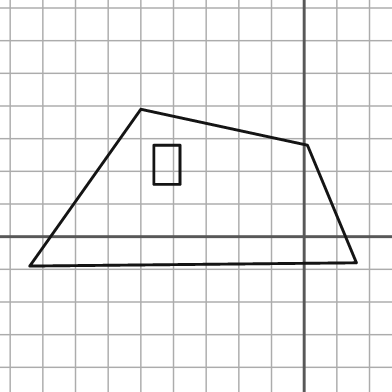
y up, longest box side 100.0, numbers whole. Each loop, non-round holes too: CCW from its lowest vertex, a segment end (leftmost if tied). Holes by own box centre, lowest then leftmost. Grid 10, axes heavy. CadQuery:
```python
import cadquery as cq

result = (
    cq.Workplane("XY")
    .moveTo(-84.0, -9.0)
    .lineTo(16.0, -8.0)
    .lineTo(1.0, 28.0)
    .lineTo(-50.0, 39.0)
    .close()
    .moveTo(-46.0, 16.0)
    .lineTo(-38.0, 16.0)
    .lineTo(-38.0, 28.0)
    .lineTo(-46.0, 28.0)
    .close()
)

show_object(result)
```